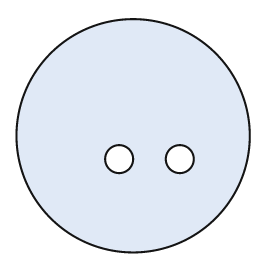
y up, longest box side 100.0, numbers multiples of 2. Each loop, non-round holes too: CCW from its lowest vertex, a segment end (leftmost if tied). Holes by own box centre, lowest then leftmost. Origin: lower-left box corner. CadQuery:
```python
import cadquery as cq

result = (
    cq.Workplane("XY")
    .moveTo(50.0, 50.0)
    .circle(50.0)
    .moveTo(44.0, 40.0)
    .circle(6.0)
    .moveTo(70.0, 40.0)
    .circle(6.0)
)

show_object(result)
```